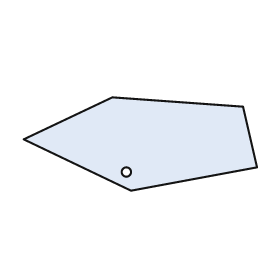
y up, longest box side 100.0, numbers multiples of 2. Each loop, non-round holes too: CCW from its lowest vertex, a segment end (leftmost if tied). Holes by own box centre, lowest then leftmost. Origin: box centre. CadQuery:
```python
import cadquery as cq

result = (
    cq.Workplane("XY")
    .moveTo(-4.0, -20.0)
    .lineTo(50.0, -10.0)
    .lineTo(44.0, 16.0)
    .lineTo(-12.0, 20.0)
    .lineTo(-50.0, 2.0)
    .close()
    .moveTo(-6.0, -12.0)
    .circle(2.0)
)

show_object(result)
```